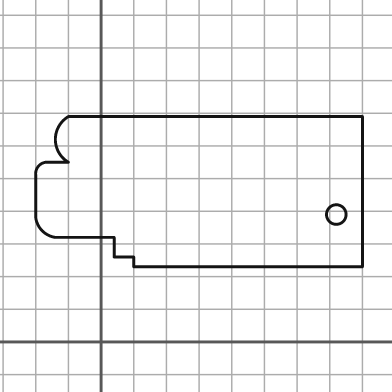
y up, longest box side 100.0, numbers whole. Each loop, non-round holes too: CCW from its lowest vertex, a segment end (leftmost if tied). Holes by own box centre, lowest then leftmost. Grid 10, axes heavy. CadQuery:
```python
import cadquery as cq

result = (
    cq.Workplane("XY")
    .moveTo(10.0, 23.0)
    .lineTo(80.0, 23.0)
    .lineTo(80.0, 69.0)
    .lineTo(-10.0, 69.0)
    .threePointArc((-14.0, 62.0), (-10.0, 55.0))
    .lineTo(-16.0, 55.0)
    .threePointArc((-19.0, 54.0), (-20.0, 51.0))
    .lineTo(-20.0, 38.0)
    .threePointArc((-18.0, 34.0), (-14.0, 32.0))
    .lineTo(4.0, 32.0)
    .lineTo(4.0, 26.0)
    .lineTo(10.0, 26.0)
    .close()
    .moveTo(72.0, 39.0)
    .circle(3.0)
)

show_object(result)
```